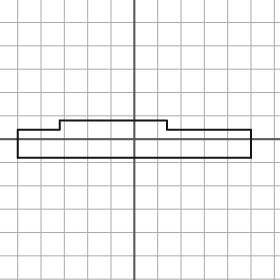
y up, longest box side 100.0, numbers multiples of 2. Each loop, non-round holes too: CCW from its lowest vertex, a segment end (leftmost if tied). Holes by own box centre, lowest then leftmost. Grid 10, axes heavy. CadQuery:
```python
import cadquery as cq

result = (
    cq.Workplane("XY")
    .moveTo(-50.0, -8.0)
    .lineTo(50.0, -8.0)
    .lineTo(50.0, 4.0)
    .lineTo(14.0, 4.0)
    .lineTo(14.0, 8.0)
    .lineTo(-32.0, 8.0)
    .lineTo(-32.0, 4.0)
    .lineTo(-50.0, 4.0)
    .close()
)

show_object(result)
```